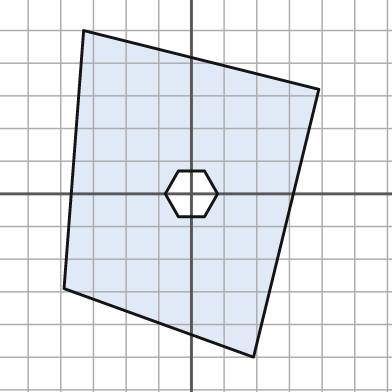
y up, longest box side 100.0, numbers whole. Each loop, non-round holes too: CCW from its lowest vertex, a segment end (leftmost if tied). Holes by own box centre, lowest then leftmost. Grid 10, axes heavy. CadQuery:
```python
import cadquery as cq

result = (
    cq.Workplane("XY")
    .moveTo(19.0, -50.0)
    .lineTo(39.0, 32.0)
    .lineTo(-33.0, 50.0)
    .lineTo(-39.0, -29.0)
    .close()
    .moveTo(-4.0, -7.0)
    .lineTo(4.0, -7.0)
    .lineTo(8.0, 0.0)
    .lineTo(4.0, 7.0)
    .lineTo(-4.0, 7.0)
    .lineTo(-8.0, 0.0)
    .close()
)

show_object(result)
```